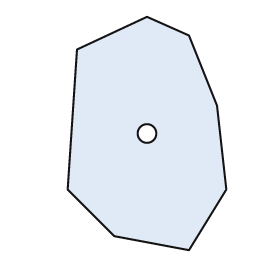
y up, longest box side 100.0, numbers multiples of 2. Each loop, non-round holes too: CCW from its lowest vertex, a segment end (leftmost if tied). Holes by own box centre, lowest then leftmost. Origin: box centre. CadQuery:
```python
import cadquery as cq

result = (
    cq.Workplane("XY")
    .moveTo(18.0, -50.0)
    .lineTo(34.0, -24.0)
    .lineTo(30.0, 12.0)
    .lineTo(18.0, 42.0)
    .lineTo(0.0, 50.0)
    .lineTo(-30.0, 36.0)
    .lineTo(-34.0, -24.0)
    .lineTo(-14.0, -44.0)
    .close()
    .moveTo(0.0, 0.0)
    .circle(4.0)
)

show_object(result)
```